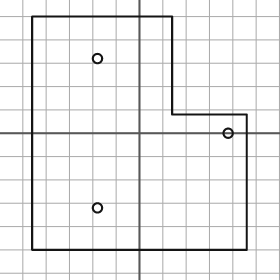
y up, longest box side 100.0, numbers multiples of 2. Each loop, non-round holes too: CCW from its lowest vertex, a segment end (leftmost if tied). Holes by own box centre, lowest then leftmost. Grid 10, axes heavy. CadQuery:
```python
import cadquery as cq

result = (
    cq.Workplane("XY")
    .moveTo(-46.0, -50.0)
    .lineTo(46.0, -50.0)
    .lineTo(46.0, 8.0)
    .lineTo(14.0, 8.0)
    .lineTo(14.0, 50.0)
    .lineTo(-46.0, 50.0)
    .close()
    .moveTo(-18.0, -32.0)
    .circle(2.0)
    .moveTo(38.0, 0.0)
    .circle(2.0)
    .moveTo(-18.0, 32.0)
    .circle(2.0)
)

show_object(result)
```